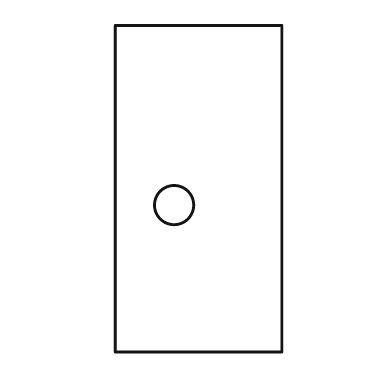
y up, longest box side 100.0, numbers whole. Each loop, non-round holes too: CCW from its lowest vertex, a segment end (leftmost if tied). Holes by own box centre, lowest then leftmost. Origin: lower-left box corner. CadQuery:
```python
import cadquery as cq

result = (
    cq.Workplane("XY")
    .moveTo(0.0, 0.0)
    .lineTo(51.0, 0.0)
    .lineTo(51.0, 100.0)
    .lineTo(0.0, 100.0)
    .close()
    .moveTo(18.0, 45.0)
    .circle(6.0)
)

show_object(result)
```